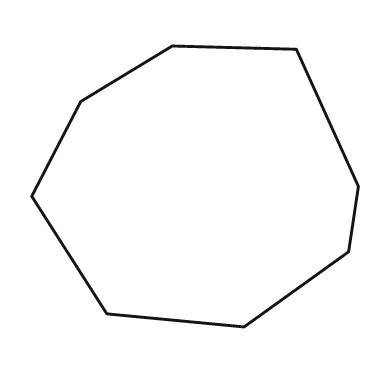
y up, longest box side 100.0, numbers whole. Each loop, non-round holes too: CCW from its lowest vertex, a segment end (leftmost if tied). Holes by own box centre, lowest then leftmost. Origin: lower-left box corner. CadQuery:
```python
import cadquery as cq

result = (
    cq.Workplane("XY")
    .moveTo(65.0, 0.0)
    .lineTo(97.0, 23.0)
    .lineTo(100.0, 43.0)
    .lineTo(81.0, 85.0)
    .lineTo(43.0, 86.0)
    .lineTo(15.0, 69.0)
    .lineTo(0.0, 40.0)
    .lineTo(23.0, 4.0)
    .close()
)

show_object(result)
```